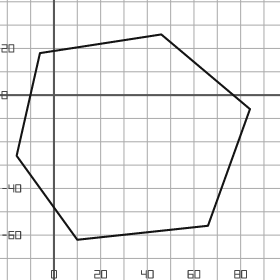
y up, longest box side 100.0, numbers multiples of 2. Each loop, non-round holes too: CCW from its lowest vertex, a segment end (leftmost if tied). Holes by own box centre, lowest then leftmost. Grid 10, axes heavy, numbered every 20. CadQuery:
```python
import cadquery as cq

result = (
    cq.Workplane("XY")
    .moveTo(10.0, -62.0)
    .lineTo(66.0, -56.0)
    .lineTo(84.0, -6.0)
    .lineTo(46.0, 26.0)
    .lineTo(-6.0, 18.0)
    .lineTo(-16.0, -26.0)
    .close()
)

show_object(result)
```